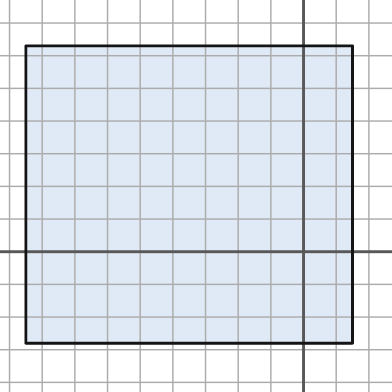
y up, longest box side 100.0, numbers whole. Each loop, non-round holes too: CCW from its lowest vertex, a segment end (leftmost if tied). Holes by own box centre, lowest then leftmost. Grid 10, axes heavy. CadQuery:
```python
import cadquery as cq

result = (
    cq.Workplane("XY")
    .moveTo(-85.0, -28.0)
    .lineTo(15.0, -28.0)
    .lineTo(15.0, 63.0)
    .lineTo(-85.0, 63.0)
    .close()
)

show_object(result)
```